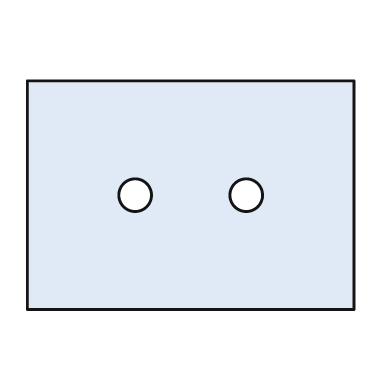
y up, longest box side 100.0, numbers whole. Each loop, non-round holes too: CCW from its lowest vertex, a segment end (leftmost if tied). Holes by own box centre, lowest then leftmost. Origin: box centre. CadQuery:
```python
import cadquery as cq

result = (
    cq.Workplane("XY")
    .moveTo(-50.0, -35.0)
    .lineTo(50.0, -35.0)
    .lineTo(50.0, 35.0)
    .lineTo(-50.0, 35.0)
    .close()
    .moveTo(-17.0, 0.0)
    .circle(5.0)
    .moveTo(17.0, 0.0)
    .circle(5.0)
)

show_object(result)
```